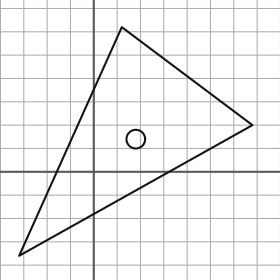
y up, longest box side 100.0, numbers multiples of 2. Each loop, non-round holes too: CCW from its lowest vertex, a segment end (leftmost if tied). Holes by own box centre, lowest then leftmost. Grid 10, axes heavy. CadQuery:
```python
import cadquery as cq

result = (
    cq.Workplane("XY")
    .moveTo(-32.0, -36.0)
    .lineTo(68.0, 20.0)
    .lineTo(12.0, 62.0)
    .close()
    .moveTo(18.0, 14.0)
    .circle(4.0)
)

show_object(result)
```